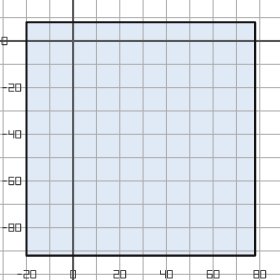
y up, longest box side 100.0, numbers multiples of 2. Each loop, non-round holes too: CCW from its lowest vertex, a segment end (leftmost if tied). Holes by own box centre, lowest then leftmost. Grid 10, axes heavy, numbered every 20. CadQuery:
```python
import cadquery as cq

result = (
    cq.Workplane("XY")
    .moveTo(-20.0, -92.0)
    .lineTo(78.0, -92.0)
    .lineTo(78.0, 8.0)
    .lineTo(-20.0, 8.0)
    .close()
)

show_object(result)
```